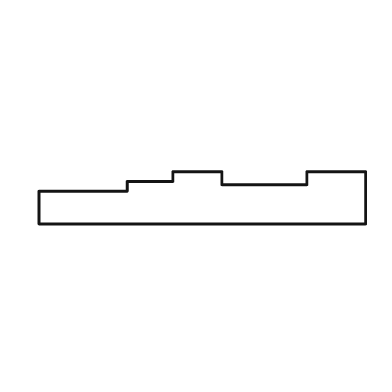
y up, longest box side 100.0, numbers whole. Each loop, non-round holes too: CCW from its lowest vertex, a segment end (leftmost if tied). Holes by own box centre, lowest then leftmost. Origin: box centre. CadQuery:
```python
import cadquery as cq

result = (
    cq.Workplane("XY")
    .moveTo(-50.0, -8.0)
    .lineTo(50.0, -8.0)
    .lineTo(50.0, 8.0)
    .lineTo(32.0, 8.0)
    .lineTo(32.0, 4.0)
    .lineTo(6.0, 4.0)
    .lineTo(6.0, 8.0)
    .lineTo(-9.0, 8.0)
    .lineTo(-9.0, 5.0)
    .lineTo(-23.0, 5.0)
    .lineTo(-23.0, 2.0)
    .lineTo(-50.0, 2.0)
    .close()
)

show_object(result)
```